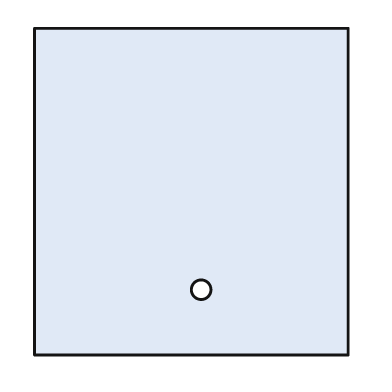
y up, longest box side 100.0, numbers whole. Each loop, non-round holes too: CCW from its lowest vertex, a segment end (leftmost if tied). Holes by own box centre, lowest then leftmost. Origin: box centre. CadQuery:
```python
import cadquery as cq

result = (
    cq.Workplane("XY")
    .moveTo(-48.0, -50.0)
    .lineTo(48.0, -50.0)
    .lineTo(48.0, 50.0)
    .lineTo(-48.0, 50.0)
    .close()
    .moveTo(3.0, -30.0)
    .circle(3.0)
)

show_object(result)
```